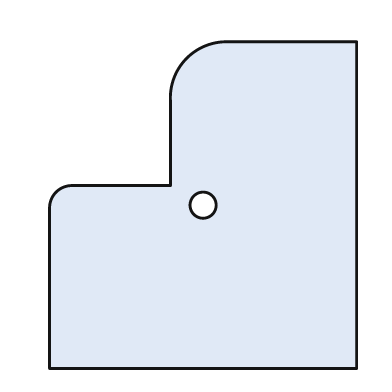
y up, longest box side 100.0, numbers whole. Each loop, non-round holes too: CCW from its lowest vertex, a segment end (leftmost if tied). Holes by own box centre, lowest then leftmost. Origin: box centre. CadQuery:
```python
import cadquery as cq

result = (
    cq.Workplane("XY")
    .moveTo(-47.0, -50.0)
    .lineTo(47.0, -50.0)
    .lineTo(47.0, 50.0)
    .lineTo(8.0, 50.0)
    .threePointArc((-5.0, 45.0), (-10.0, 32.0))
    .lineTo(-10.0, 6.0)
    .lineTo(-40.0, 6.0)
    .threePointArc((-45.0, 4.0), (-47.0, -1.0))
    .close()
    .moveTo(0.0, 0.0)
    .circle(4.0)
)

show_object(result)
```